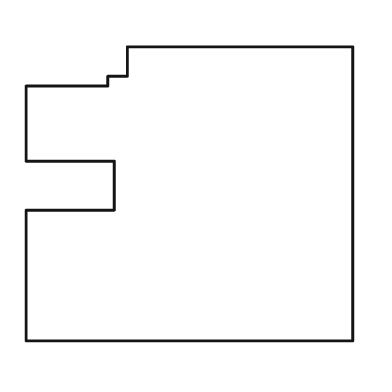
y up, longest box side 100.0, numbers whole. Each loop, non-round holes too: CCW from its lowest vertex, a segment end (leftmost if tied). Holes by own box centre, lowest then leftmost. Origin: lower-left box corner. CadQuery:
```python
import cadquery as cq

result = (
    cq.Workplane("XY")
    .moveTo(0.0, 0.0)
    .lineTo(100.0, 0.0)
    .lineTo(100.0, 90.0)
    .lineTo(31.0, 90.0)
    .lineTo(31.0, 81.0)
    .lineTo(25.0, 81.0)
    .lineTo(25.0, 78.0)
    .lineTo(0.0, 78.0)
    .lineTo(0.0, 55.0)
    .lineTo(27.0, 55.0)
    .lineTo(27.0, 40.0)
    .lineTo(0.0, 40.0)
    .close()
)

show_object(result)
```